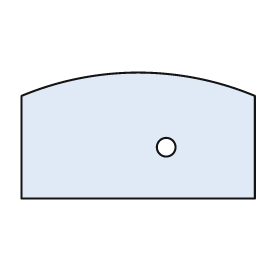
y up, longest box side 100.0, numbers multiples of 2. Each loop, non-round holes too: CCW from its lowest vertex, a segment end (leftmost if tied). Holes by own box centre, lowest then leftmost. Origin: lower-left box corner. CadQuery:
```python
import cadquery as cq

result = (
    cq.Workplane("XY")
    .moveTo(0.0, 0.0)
    .lineTo(100.0, 0.0)
    .lineTo(100.0, 44.0)
    .threePointArc((50.0, 54.0), (0.0, 44.0))
    .close()
    .moveTo(62.0, 22.0)
    .circle(4.0)
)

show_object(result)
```